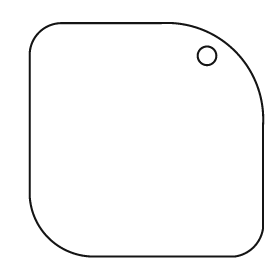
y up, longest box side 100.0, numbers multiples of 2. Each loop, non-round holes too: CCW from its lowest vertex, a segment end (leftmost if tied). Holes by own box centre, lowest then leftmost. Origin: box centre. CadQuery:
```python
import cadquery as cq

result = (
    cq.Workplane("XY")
    .moveTo(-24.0, -50.0)
    .lineTo(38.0, -50.0)
    .threePointArc((46.0, -46.0), (50.0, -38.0))
    .lineTo(50.0, 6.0)
    .threePointArc((38.0, 38.0), (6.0, 50.0))
    .lineTo(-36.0, 50.0)
    .threePointArc((-46.0, 46.0), (-50.0, 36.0))
    .lineTo(-50.0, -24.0)
    .threePointArc((-42.0, -42.0), (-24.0, -50.0))
    .close()
    .moveTo(26.0, 36.0)
    .circle(4.0)
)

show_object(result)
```